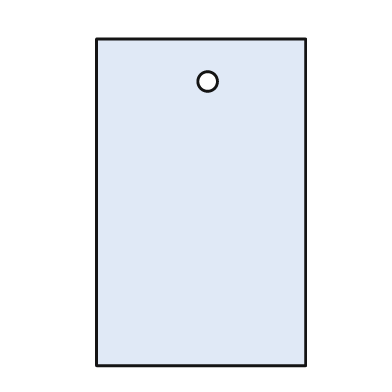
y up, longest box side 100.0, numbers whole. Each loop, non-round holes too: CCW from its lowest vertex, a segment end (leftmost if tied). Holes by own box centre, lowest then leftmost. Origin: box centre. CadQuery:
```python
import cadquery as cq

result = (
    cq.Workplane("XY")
    .moveTo(-32.0, -50.0)
    .lineTo(32.0, -50.0)
    .lineTo(32.0, 50.0)
    .lineTo(-32.0, 50.0)
    .close()
    .moveTo(2.0, 37.0)
    .circle(3.0)
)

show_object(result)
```